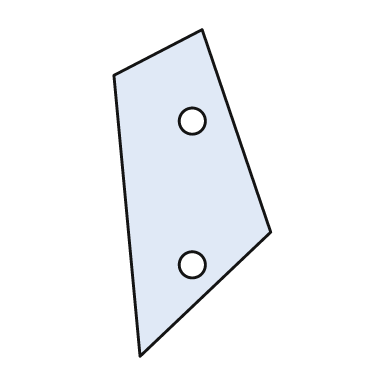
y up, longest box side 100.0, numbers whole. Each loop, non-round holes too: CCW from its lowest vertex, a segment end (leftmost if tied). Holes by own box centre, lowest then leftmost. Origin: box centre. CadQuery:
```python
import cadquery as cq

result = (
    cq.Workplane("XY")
    .moveTo(-16.0, -50.0)
    .lineTo(24.0, -12.0)
    .lineTo(3.0, 50.0)
    .lineTo(-24.0, 36.0)
    .close()
    .moveTo(0.0, -22.0)
    .circle(4.0)
    .moveTo(0.0, 22.0)
    .circle(4.0)
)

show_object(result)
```